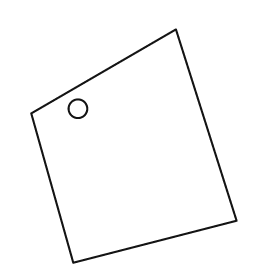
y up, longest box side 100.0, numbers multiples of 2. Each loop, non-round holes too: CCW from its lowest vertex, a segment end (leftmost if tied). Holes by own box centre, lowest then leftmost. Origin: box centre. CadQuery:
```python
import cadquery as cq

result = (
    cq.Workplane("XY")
    .moveTo(-26.0, -50.0)
    .lineTo(44.0, -32.0)
    .lineTo(18.0, 50.0)
    .lineTo(-44.0, 14.0)
    .close()
    .moveTo(-24.0, 16.0)
    .circle(4.0)
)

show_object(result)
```